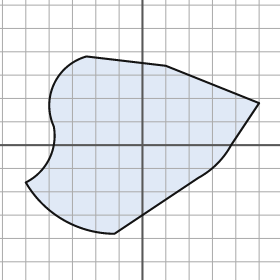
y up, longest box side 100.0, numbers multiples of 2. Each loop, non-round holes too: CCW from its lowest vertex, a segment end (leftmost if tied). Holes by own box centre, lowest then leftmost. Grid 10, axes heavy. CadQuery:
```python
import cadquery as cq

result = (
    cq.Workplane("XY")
    .moveTo(-12.0, -38.0)
    .lineTo(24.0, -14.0)
    .threePointArc((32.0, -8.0), (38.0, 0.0))
    .lineTo(50.0, 18.0)
    .lineTo(10.0, 34.0)
    .lineTo(-24.0, 38.0)
    .threePointArc((-38.0, 26.0), (-38.0, 8.0))
    .threePointArc((-40.0, -6.0), (-50.0, -16.0))
    .threePointArc((-34.0, -32.0), (-12.0, -38.0))
    .close()
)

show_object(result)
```